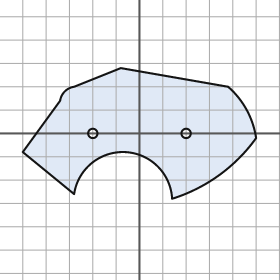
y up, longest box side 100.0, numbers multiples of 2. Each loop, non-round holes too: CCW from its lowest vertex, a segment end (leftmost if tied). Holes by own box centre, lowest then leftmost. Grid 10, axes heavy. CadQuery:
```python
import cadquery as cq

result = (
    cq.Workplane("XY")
    .moveTo(14.0, -28.0)
    .threePointArc((34.0, -18.0), (50.0, -2.0))
    .threePointArc((46.0, 10.0), (38.0, 20.0))
    .lineTo(-8.0, 28.0)
    .lineTo(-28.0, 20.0)
    .threePointArc((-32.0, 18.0), (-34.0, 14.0))
    .lineTo(-50.0, -8.0)
    .lineTo(-28.0, -26.0)
    .threePointArc((-6.0, -8.0), (14.0, -28.0))
    .close()
    .moveTo(-20.0, 0.0)
    .circle(2.0)
    .moveTo(20.0, 0.0)
    .circle(2.0)
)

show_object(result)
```